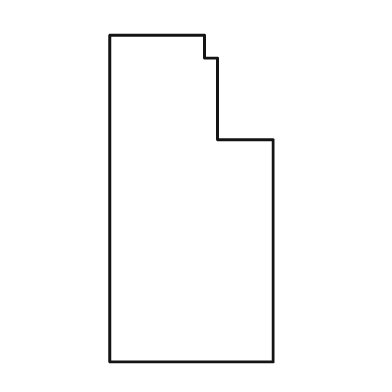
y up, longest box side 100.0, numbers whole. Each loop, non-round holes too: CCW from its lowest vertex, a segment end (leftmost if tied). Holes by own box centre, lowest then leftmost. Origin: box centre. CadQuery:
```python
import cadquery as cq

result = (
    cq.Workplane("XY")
    .moveTo(-25.0, -50.0)
    .lineTo(25.0, -50.0)
    .lineTo(25.0, 18.0)
    .lineTo(8.0, 18.0)
    .lineTo(8.0, 43.0)
    .lineTo(4.0, 43.0)
    .lineTo(4.0, 50.0)
    .lineTo(-25.0, 50.0)
    .close()
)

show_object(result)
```